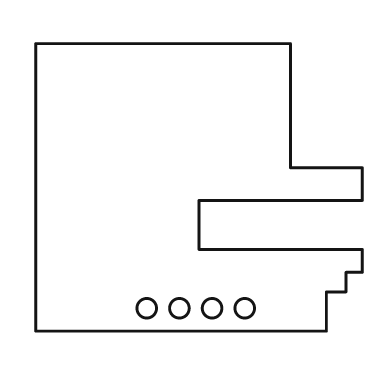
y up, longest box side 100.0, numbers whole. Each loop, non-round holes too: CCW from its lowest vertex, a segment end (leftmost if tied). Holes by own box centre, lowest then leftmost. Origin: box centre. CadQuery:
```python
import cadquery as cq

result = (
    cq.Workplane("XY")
    .moveTo(-50.0, -44.0)
    .lineTo(39.0, -44.0)
    .lineTo(39.0, -32.0)
    .lineTo(45.0, -32.0)
    .lineTo(45.0, -26.0)
    .lineTo(50.0, -26.0)
    .lineTo(50.0, -19.0)
    .lineTo(0.0, -19.0)
    .lineTo(0.0, -4.0)
    .lineTo(50.0, -4.0)
    .lineTo(50.0, 6.0)
    .lineTo(28.0, 6.0)
    .lineTo(28.0, 44.0)
    .lineTo(-50.0, 44.0)
    .close()
    .moveTo(-16.0, -37.0)
    .circle(3.0)
    .moveTo(-6.0, -37.0)
    .circle(3.0)
    .moveTo(4.0, -37.0)
    .circle(3.0)
    .moveTo(14.0, -37.0)
    .circle(3.0)
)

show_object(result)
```